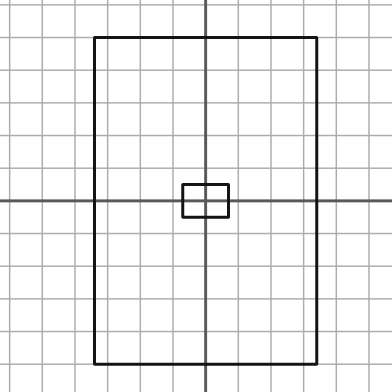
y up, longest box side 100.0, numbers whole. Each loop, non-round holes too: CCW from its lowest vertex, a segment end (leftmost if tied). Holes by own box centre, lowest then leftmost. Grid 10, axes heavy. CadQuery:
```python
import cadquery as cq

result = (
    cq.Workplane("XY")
    .moveTo(-34.0, -50.0)
    .lineTo(34.0, -50.0)
    .lineTo(34.0, 50.0)
    .lineTo(-34.0, 50.0)
    .close()
    .moveTo(-7.0, -5.0)
    .lineTo(7.0, -5.0)
    .lineTo(7.0, 5.0)
    .lineTo(-7.0, 5.0)
    .close()
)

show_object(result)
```